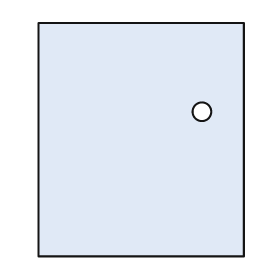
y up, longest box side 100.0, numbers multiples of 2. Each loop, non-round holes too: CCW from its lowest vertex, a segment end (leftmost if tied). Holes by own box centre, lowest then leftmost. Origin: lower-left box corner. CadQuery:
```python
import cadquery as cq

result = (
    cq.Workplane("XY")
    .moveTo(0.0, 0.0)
    .lineTo(88.0, 0.0)
    .lineTo(88.0, 100.0)
    .lineTo(0.0, 100.0)
    .close()
    .moveTo(70.0, 62.0)
    .circle(4.0)
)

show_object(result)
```